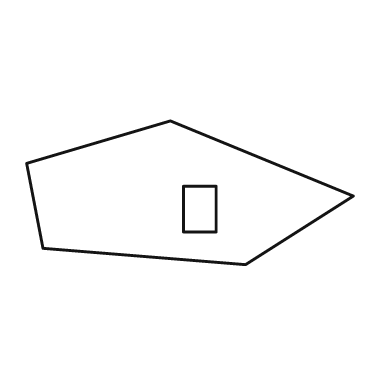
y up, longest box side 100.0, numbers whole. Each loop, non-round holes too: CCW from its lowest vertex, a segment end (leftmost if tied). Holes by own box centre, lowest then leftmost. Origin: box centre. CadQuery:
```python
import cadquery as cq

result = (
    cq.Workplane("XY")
    .moveTo(17.0, -22.0)
    .lineTo(50.0, -1.0)
    .lineTo(-6.0, 22.0)
    .lineTo(-50.0, 9.0)
    .lineTo(-45.0, -17.0)
    .close()
    .moveTo(-2.0, -12.0)
    .lineTo(8.0, -12.0)
    .lineTo(8.0, 2.0)
    .lineTo(-2.0, 2.0)
    .close()
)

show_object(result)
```